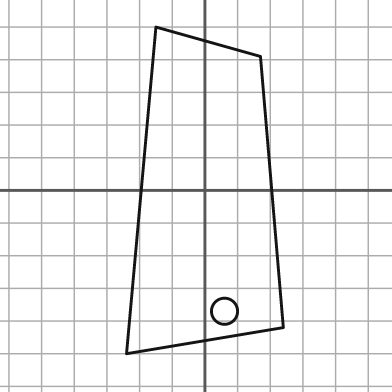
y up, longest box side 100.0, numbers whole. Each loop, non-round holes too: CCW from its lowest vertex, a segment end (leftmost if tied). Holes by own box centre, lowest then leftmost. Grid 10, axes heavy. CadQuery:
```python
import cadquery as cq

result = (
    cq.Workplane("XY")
    .moveTo(-24.0, -50.0)
    .lineTo(24.0, -42.0)
    .lineTo(17.0, 41.0)
    .lineTo(-15.0, 50.0)
    .close()
    .moveTo(6.0, -37.0)
    .circle(4.0)
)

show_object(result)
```